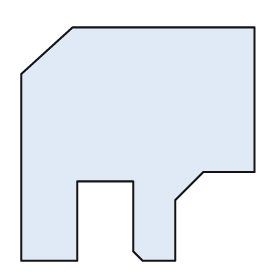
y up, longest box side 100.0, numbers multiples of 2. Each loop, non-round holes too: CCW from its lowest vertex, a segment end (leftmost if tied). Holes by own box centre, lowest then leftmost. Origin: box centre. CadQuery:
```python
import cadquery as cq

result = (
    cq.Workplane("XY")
    .moveTo(-50.0, -50.0)
    .lineTo(-26.0, -50.0)
    .lineTo(-26.0, -16.0)
    .lineTo(-2.0, -16.0)
    .lineTo(-2.0, -46.0)
    .lineTo(2.0, -50.0)
    .lineTo(16.0, -50.0)
    .lineTo(16.0, -24.0)
    .lineTo(28.0, -12.0)
    .lineTo(50.0, -12.0)
    .lineTo(50.0, 50.0)
    .lineTo(-28.0, 50.0)
    .lineTo(-50.0, 30.0)
    .close()
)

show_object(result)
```